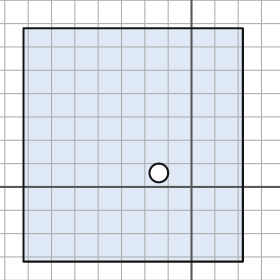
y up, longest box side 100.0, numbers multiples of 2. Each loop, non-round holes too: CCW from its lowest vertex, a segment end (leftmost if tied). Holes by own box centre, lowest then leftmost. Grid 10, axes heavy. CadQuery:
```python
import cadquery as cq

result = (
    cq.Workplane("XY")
    .moveTo(-72.0, -32.0)
    .lineTo(22.0, -32.0)
    .lineTo(22.0, 68.0)
    .lineTo(-72.0, 68.0)
    .close()
    .moveTo(-14.0, 6.0)
    .circle(4.0)
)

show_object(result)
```